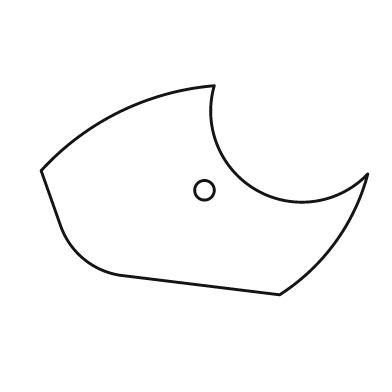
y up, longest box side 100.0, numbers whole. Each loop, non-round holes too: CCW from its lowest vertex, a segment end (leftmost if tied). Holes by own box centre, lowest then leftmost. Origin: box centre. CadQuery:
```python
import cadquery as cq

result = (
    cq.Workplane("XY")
    .moveTo(23.0, -32.0)
    .threePointArc((40.0, -16.0), (50.0, 5.0))
    .threePointArc((16.0, 0.0), (3.0, 32.0))
    .threePointArc((-26.0, 24.0), (-50.0, 6.0))
    .lineTo(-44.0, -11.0)
    .threePointArc((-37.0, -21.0), (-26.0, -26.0))
    .close()
    .moveTo(0.0, 0.0)
    .circle(3.0)
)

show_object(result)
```